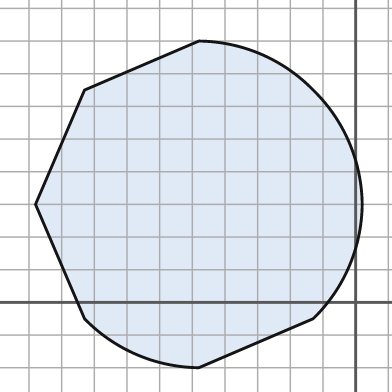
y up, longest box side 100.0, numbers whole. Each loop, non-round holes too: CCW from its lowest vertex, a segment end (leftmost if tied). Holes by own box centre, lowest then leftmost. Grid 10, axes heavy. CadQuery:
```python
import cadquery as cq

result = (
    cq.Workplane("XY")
    .moveTo(-48.0, -20.0)
    .lineTo(-13.0, -5.0)
    .threePointArc((-2.0, 11.0), (2.0, 30.0))
    .threePointArc((-2.0, 49.0), (-13.0, 65.0))
    .threePointArc((-29.0, 76.0), (-48.0, 80.0))
    .lineTo(-83.0, 65.0)
    .lineTo(-98.0, 30.0)
    .lineTo(-83.0, -5.0)
    .threePointArc((-67.0, -16.0), (-48.0, -20.0))
    .close()
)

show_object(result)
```